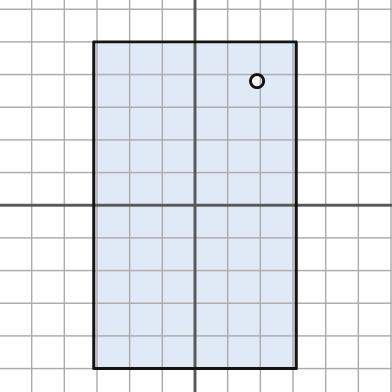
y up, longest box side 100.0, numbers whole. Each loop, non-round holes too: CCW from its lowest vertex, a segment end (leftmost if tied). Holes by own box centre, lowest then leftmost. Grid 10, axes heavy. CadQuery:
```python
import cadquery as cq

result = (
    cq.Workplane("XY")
    .moveTo(-31.0, -50.0)
    .lineTo(31.0, -50.0)
    .lineTo(31.0, 50.0)
    .lineTo(-31.0, 50.0)
    .close()
    .moveTo(19.0, 38.0)
    .circle(2.0)
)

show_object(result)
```